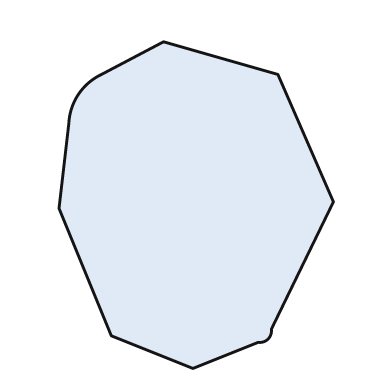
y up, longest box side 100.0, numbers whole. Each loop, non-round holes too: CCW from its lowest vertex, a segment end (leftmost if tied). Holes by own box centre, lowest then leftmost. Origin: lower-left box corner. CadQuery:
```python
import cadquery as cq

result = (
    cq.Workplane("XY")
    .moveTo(41.0, 0.0)
    .lineTo(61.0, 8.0)
    .threePointArc((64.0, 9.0), (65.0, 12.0))
    .lineTo(84.0, 51.0)
    .lineTo(67.0, 90.0)
    .lineTo(32.0, 100.0)
    .lineTo(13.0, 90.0)
    .threePointArc((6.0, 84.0), (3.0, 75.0))
    .lineTo(0.0, 49.0)
    .lineTo(16.0, 10.0)
    .close()
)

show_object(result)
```